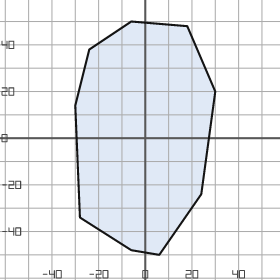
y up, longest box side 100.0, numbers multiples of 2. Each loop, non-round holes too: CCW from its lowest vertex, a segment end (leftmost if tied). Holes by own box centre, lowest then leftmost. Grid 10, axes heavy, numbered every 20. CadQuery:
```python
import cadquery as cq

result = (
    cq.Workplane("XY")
    .moveTo(6.0, -50.0)
    .lineTo(24.0, -24.0)
    .lineTo(30.0, 20.0)
    .lineTo(18.0, 48.0)
    .lineTo(-6.0, 50.0)
    .lineTo(-24.0, 38.0)
    .lineTo(-30.0, 14.0)
    .lineTo(-28.0, -34.0)
    .lineTo(-6.0, -48.0)
    .close()
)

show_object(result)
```